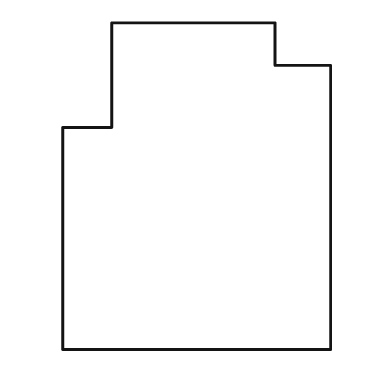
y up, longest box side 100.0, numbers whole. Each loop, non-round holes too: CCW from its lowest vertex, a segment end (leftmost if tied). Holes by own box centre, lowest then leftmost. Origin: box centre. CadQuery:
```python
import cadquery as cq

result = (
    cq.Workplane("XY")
    .moveTo(-41.0, -50.0)
    .lineTo(41.0, -50.0)
    .lineTo(41.0, 37.0)
    .lineTo(24.0, 37.0)
    .lineTo(24.0, 50.0)
    .lineTo(-26.0, 50.0)
    .lineTo(-26.0, 18.0)
    .lineTo(-41.0, 18.0)
    .close()
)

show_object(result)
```